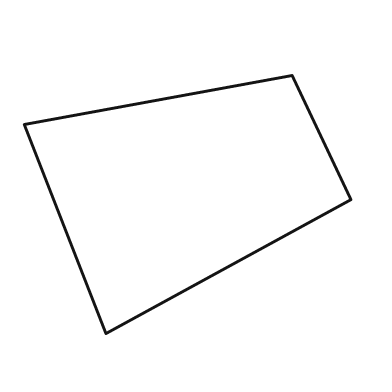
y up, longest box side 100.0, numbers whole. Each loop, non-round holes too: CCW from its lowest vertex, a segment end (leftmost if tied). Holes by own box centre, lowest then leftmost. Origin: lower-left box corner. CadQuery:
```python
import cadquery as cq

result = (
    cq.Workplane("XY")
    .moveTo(25.0, 0.0)
    .lineTo(100.0, 41.0)
    .lineTo(82.0, 79.0)
    .lineTo(0.0, 64.0)
    .close()
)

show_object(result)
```